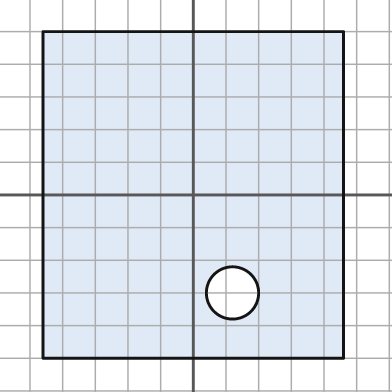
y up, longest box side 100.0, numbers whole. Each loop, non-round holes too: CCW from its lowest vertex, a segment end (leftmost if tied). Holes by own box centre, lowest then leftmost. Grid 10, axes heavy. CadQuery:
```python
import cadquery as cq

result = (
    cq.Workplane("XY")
    .moveTo(-46.0, -50.0)
    .lineTo(46.0, -50.0)
    .lineTo(46.0, 50.0)
    .lineTo(-46.0, 50.0)
    .close()
    .moveTo(12.0, -30.0)
    .circle(8.0)
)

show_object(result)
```